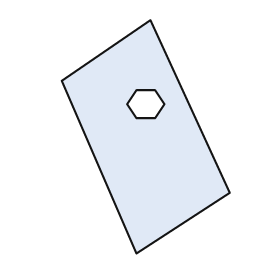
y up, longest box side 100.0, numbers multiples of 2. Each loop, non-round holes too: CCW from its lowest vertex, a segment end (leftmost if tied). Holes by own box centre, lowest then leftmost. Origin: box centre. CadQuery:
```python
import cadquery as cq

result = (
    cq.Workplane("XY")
    .moveTo(-4.0, -50.0)
    .lineTo(36.0, -24.0)
    .lineTo(2.0, 50.0)
    .lineTo(-36.0, 24.0)
    .close()
    .moveTo(-4.0, 8.0)
    .lineTo(4.0, 8.0)
    .lineTo(8.0, 14.0)
    .lineTo(4.0, 20.0)
    .lineTo(-4.0, 20.0)
    .lineTo(-8.0, 14.0)
    .close()
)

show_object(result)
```